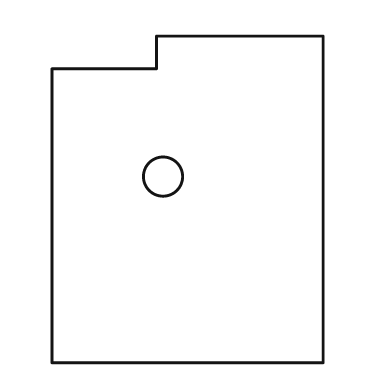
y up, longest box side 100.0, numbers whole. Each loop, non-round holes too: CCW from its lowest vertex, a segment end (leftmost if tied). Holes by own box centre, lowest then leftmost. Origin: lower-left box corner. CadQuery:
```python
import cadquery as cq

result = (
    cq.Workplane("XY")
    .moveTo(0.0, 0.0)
    .lineTo(83.0, 0.0)
    .lineTo(83.0, 100.0)
    .lineTo(32.0, 100.0)
    .lineTo(32.0, 90.0)
    .lineTo(0.0, 90.0)
    .close()
    .moveTo(34.0, 57.0)
    .circle(6.0)
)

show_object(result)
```